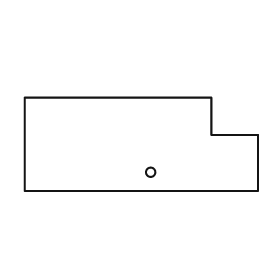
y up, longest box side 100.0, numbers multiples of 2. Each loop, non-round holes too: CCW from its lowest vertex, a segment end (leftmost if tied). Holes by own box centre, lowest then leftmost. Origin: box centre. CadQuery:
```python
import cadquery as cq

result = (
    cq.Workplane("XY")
    .moveTo(-50.0, -20.0)
    .lineTo(50.0, -20.0)
    .lineTo(50.0, 4.0)
    .lineTo(30.0, 4.0)
    .lineTo(30.0, 20.0)
    .lineTo(-50.0, 20.0)
    .close()
    .moveTo(4.0, -12.0)
    .circle(2.0)
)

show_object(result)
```